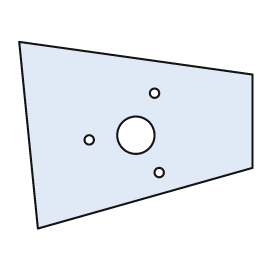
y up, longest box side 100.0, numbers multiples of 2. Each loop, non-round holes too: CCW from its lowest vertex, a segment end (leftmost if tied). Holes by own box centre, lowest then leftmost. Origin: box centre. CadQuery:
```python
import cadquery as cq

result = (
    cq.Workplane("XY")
    .moveTo(-42.0, -40.0)
    .lineTo(50.0, -14.0)
    .lineTo(50.0, 26.0)
    .lineTo(-50.0, 40.0)
    .close()
    .moveTo(10.0, -16.0)
    .circle(2.0)
    .moveTo(-20.0, -2.0)
    .circle(2.0)
    .moveTo(0.0, 0.0)
    .circle(8.0)
    .moveTo(8.0, 18.0)
    .circle(2.0)
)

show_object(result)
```